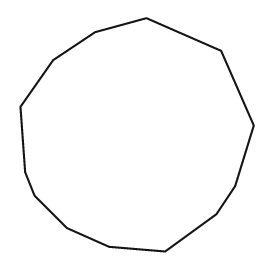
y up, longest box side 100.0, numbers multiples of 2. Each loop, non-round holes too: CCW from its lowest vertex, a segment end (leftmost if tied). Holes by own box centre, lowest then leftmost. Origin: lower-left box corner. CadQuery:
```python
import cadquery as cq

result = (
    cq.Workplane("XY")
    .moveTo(62.0, 0.0)
    .lineTo(84.0, 16.0)
    .lineTo(92.0, 28.0)
    .lineTo(100.0, 54.0)
    .lineTo(86.0, 86.0)
    .lineTo(54.0, 100.0)
    .lineTo(32.0, 94.0)
    .lineTo(14.0, 82.0)
    .lineTo(0.0, 62.0)
    .lineTo(2.0, 34.0)
    .lineTo(6.0, 24.0)
    .lineTo(20.0, 10.0)
    .lineTo(38.0, 2.0)
    .close()
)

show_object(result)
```